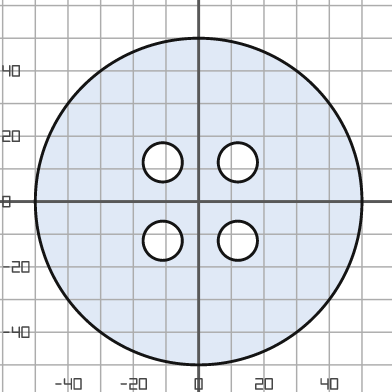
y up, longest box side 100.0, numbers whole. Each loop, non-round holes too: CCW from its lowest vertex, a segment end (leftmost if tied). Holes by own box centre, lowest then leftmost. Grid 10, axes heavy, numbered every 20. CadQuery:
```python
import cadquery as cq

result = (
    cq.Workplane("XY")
    .moveTo(0.0, 0.0)
    .circle(50.0)
    .moveTo(-11.0, -12.0)
    .circle(6.0)
    .moveTo(12.0, -12.0)
    .circle(6.0)
    .moveTo(-11.0, 12.0)
    .circle(6.0)
    .moveTo(12.0, 12.0)
    .circle(6.0)
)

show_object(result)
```